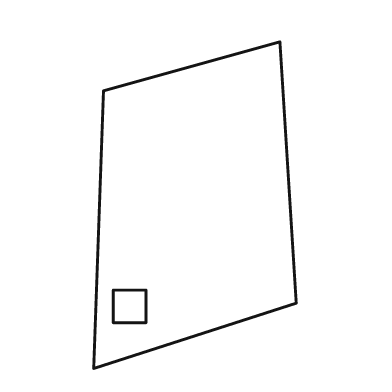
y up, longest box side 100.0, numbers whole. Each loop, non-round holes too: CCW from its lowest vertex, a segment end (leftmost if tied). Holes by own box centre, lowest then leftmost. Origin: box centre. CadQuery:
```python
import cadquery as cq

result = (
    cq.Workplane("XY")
    .moveTo(-31.0, -50.0)
    .lineTo(31.0, -30.0)
    .lineTo(26.0, 50.0)
    .lineTo(-28.0, 35.0)
    .close()
    .moveTo(-25.0, -36.0)
    .lineTo(-15.0, -36.0)
    .lineTo(-15.0, -26.0)
    .lineTo(-25.0, -26.0)
    .close()
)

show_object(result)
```